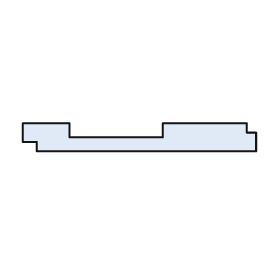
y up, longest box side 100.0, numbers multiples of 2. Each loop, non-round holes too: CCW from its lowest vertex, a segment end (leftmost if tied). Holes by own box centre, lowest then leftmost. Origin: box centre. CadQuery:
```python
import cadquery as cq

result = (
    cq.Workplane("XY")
    .moveTo(-44.0, -6.0)
    .lineTo(50.0, -6.0)
    .lineTo(50.0, 2.0)
    .lineTo(46.0, 2.0)
    .lineTo(46.0, 6.0)
    .lineTo(10.0, 6.0)
    .lineTo(10.0, 0.0)
    .lineTo(-30.0, 0.0)
    .lineTo(-30.0, 6.0)
    .lineTo(-50.0, 6.0)
    .lineTo(-50.0, -2.0)
    .lineTo(-44.0, -2.0)
    .close()
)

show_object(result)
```